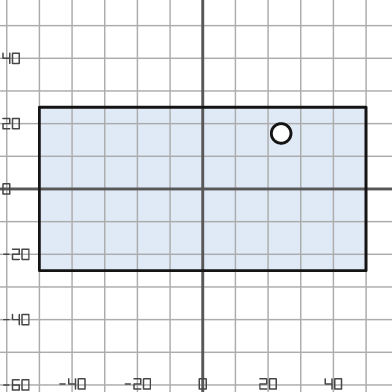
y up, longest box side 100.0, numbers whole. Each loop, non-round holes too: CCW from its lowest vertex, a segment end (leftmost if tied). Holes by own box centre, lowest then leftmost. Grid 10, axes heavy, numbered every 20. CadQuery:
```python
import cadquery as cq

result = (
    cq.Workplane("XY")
    .moveTo(-50.0, -25.0)
    .lineTo(50.0, -25.0)
    .lineTo(50.0, 25.0)
    .lineTo(-50.0, 25.0)
    .close()
    .moveTo(24.0, 17.0)
    .circle(3.0)
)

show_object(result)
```